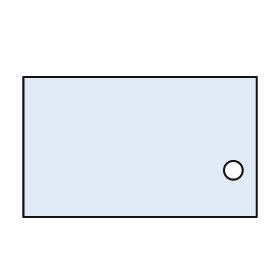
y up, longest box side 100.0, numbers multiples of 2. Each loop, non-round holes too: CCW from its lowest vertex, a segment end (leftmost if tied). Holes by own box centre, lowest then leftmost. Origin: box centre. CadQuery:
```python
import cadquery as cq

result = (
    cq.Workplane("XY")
    .moveTo(-50.0, -30.0)
    .lineTo(50.0, -30.0)
    .lineTo(50.0, 30.0)
    .lineTo(-50.0, 30.0)
    .close()
    .moveTo(40.0, -10.0)
    .circle(4.0)
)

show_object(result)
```